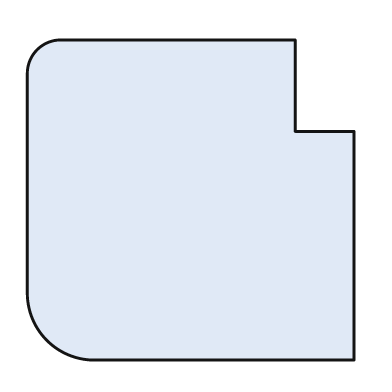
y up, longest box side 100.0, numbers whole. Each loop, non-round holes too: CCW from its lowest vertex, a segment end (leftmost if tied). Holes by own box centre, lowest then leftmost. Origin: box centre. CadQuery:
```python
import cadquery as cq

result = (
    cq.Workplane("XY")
    .moveTo(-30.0, -49.0)
    .lineTo(50.0, -49.0)
    .lineTo(50.0, 21.0)
    .lineTo(32.0, 21.0)
    .lineTo(32.0, 49.0)
    .lineTo(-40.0, 49.0)
    .threePointArc((-47.0, 46.0), (-50.0, 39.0))
    .lineTo(-50.0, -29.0)
    .threePointArc((-44.0, -43.0), (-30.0, -49.0))
    .close()
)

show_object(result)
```